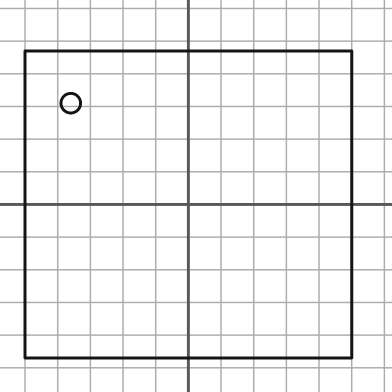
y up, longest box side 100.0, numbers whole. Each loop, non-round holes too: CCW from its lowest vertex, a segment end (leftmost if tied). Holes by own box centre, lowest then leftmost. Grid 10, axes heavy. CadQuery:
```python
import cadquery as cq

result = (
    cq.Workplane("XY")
    .moveTo(-50.0, -47.0)
    .lineTo(50.0, -47.0)
    .lineTo(50.0, 47.0)
    .lineTo(-50.0, 47.0)
    .close()
    .moveTo(-36.0, 31.0)
    .circle(3.0)
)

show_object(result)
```